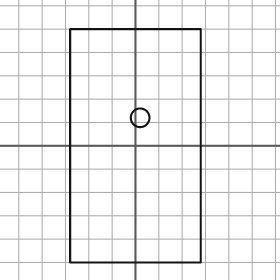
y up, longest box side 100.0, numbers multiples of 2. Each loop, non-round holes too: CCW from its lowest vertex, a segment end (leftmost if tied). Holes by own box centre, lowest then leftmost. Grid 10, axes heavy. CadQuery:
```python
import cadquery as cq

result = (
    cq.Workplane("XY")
    .moveTo(-28.0, -50.0)
    .lineTo(28.0, -50.0)
    .lineTo(28.0, 50.0)
    .lineTo(-28.0, 50.0)
    .close()
    .moveTo(2.0, 12.0)
    .circle(4.0)
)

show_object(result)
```